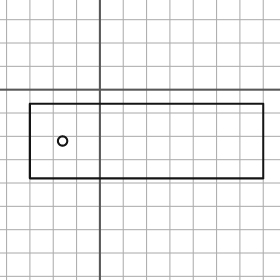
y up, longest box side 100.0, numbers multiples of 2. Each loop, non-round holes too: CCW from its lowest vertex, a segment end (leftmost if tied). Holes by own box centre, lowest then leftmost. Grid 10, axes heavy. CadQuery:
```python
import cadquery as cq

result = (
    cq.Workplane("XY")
    .moveTo(-30.0, -38.0)
    .lineTo(70.0, -38.0)
    .lineTo(70.0, -6.0)
    .lineTo(-30.0, -6.0)
    .close()
    .moveTo(-16.0, -22.0)
    .circle(2.0)
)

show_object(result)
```